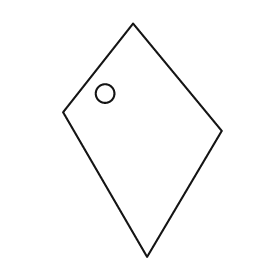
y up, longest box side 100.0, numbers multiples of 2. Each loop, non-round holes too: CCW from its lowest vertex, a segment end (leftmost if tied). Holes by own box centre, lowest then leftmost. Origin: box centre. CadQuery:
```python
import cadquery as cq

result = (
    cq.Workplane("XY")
    .moveTo(2.0, -50.0)
    .lineTo(34.0, 4.0)
    .lineTo(-4.0, 50.0)
    .lineTo(-34.0, 12.0)
    .close()
    .moveTo(-16.0, 20.0)
    .circle(4.0)
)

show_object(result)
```